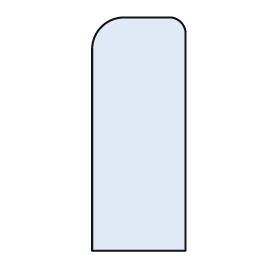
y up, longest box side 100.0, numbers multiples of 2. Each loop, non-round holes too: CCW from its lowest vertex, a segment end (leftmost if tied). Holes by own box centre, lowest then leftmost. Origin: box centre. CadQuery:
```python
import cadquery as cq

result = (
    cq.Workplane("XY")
    .moveTo(-20.0, -50.0)
    .lineTo(20.0, -50.0)
    .lineTo(20.0, 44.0)
    .threePointArc((18.0, 48.0), (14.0, 50.0))
    .lineTo(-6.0, 50.0)
    .threePointArc((-16.0, 46.0), (-20.0, 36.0))
    .close()
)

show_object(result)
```